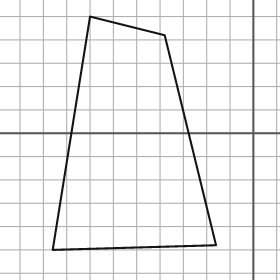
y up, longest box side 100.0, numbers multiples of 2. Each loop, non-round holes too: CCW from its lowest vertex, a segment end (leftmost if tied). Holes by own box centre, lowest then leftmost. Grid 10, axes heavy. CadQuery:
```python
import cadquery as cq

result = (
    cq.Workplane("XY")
    .moveTo(-86.0, -50.0)
    .lineTo(-16.0, -48.0)
    .lineTo(-38.0, 42.0)
    .lineTo(-70.0, 50.0)
    .close()
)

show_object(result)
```